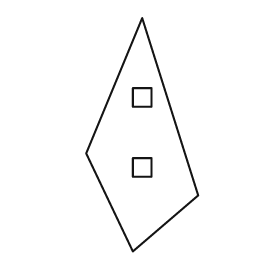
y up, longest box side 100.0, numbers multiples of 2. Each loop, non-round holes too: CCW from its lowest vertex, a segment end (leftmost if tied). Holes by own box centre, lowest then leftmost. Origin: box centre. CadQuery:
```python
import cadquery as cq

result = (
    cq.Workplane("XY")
    .moveTo(-4.0, -50.0)
    .lineTo(24.0, -26.0)
    .lineTo(0.0, 50.0)
    .lineTo(-24.0, -8.0)
    .close()
    .moveTo(-4.0, -18.0)
    .lineTo(4.0, -18.0)
    .lineTo(4.0, -10.0)
    .lineTo(-4.0, -10.0)
    .close()
    .moveTo(-4.0, 12.0)
    .lineTo(4.0, 12.0)
    .lineTo(4.0, 20.0)
    .lineTo(-4.0, 20.0)
    .close()
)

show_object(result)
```